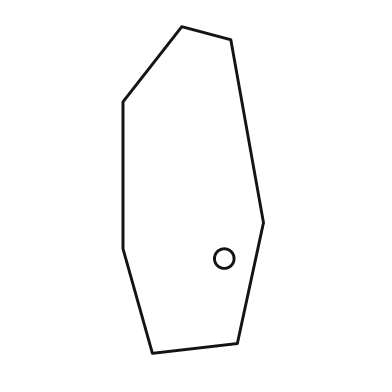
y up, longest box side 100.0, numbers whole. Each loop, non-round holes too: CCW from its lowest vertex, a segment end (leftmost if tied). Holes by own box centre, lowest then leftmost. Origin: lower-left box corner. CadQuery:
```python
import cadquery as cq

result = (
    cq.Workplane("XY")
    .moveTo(9.0, 0.0)
    .lineTo(35.0, 3.0)
    .lineTo(43.0, 40.0)
    .lineTo(33.0, 96.0)
    .lineTo(18.0, 100.0)
    .lineTo(0.0, 77.0)
    .lineTo(0.0, 32.0)
    .close()
    .moveTo(31.0, 29.0)
    .circle(3.0)
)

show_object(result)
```